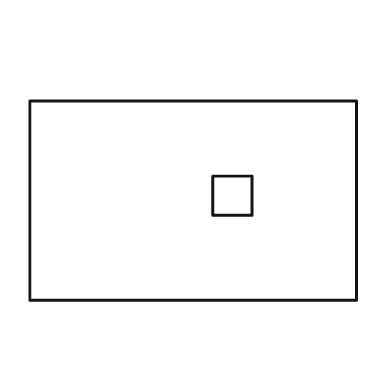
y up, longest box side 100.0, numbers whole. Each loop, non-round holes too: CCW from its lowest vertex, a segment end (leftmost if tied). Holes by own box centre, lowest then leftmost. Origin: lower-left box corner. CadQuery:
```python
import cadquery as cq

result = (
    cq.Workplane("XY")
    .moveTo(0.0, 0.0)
    .lineTo(100.0, 0.0)
    .lineTo(100.0, 61.0)
    .lineTo(0.0, 61.0)
    .close()
    .moveTo(56.0, 26.0)
    .lineTo(68.0, 26.0)
    .lineTo(68.0, 38.0)
    .lineTo(56.0, 38.0)
    .close()
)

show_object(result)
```